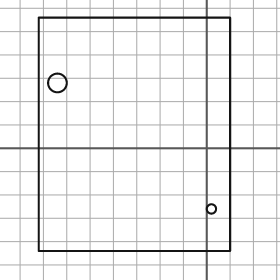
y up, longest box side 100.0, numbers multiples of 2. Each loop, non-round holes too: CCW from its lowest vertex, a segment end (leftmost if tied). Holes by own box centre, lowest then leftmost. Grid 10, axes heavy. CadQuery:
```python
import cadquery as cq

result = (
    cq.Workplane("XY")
    .moveTo(-72.0, -44.0)
    .lineTo(10.0, -44.0)
    .lineTo(10.0, 56.0)
    .lineTo(-72.0, 56.0)
    .close()
    .moveTo(2.0, -26.0)
    .circle(2.0)
    .moveTo(-64.0, 28.0)
    .circle(4.0)
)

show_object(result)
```